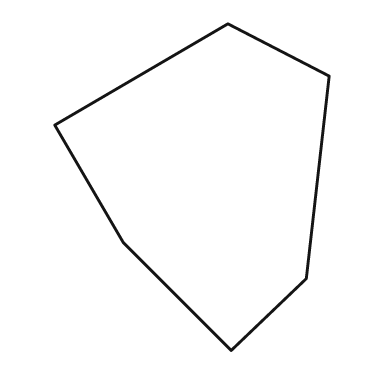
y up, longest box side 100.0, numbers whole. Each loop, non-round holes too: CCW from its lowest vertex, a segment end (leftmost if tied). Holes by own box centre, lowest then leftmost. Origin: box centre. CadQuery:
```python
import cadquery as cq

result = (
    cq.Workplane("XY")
    .moveTo(12.0, -50.0)
    .lineTo(35.0, -28.0)
    .lineTo(42.0, 34.0)
    .lineTo(11.0, 50.0)
    .lineTo(-42.0, 19.0)
    .lineTo(-21.0, -17.0)
    .close()
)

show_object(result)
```